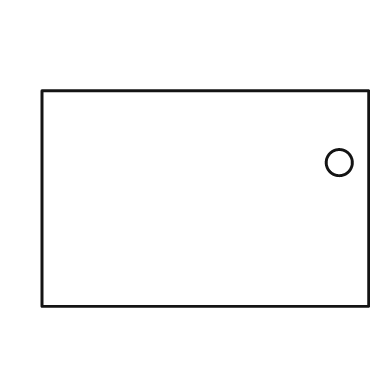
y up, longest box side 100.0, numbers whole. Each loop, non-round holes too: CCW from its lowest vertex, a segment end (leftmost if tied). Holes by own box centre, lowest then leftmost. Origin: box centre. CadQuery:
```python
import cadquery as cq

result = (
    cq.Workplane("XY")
    .moveTo(-50.0, -33.0)
    .lineTo(50.0, -33.0)
    .lineTo(50.0, 33.0)
    .lineTo(-50.0, 33.0)
    .close()
    .moveTo(41.0, 11.0)
    .circle(4.0)
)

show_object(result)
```